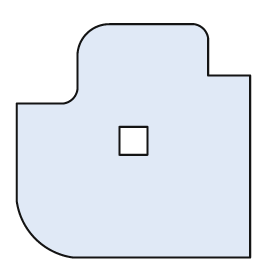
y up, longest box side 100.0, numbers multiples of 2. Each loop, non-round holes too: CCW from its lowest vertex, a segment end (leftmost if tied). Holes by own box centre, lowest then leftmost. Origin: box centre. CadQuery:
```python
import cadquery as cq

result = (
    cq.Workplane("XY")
    .moveTo(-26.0, -50.0)
    .lineTo(50.0, -50.0)
    .lineTo(50.0, 28.0)
    .lineTo(32.0, 28.0)
    .lineTo(32.0, 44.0)
    .threePointArc((30.0, 48.0), (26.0, 50.0))
    .lineTo(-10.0, 50.0)
    .threePointArc((-20.0, 46.0), (-24.0, 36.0))
    .lineTo(-24.0, 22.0)
    .threePointArc((-26.0, 18.0), (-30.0, 16.0))
    .lineTo(-50.0, 16.0)
    .lineTo(-50.0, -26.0)
    .threePointArc((-42.0, -42.0), (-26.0, -50.0))
    .close()
    .moveTo(-6.0, -6.0)
    .lineTo(6.0, -6.0)
    .lineTo(6.0, 6.0)
    .lineTo(-6.0, 6.0)
    .close()
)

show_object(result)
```